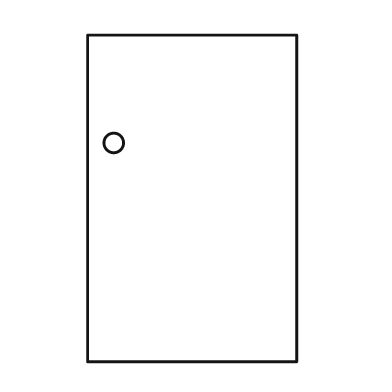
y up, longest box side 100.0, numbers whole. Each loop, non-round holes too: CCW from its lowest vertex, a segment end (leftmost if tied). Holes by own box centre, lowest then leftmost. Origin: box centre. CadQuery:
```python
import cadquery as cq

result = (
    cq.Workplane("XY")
    .moveTo(-32.0, -50.0)
    .lineTo(32.0, -50.0)
    .lineTo(32.0, 50.0)
    .lineTo(-32.0, 50.0)
    .close()
    .moveTo(-24.0, 17.0)
    .circle(3.0)
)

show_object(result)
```